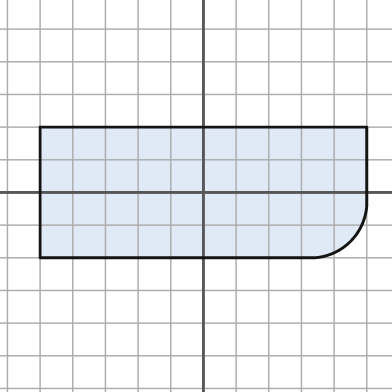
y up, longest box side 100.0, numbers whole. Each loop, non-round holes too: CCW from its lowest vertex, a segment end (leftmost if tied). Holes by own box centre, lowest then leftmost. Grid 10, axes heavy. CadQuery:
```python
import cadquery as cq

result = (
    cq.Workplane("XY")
    .moveTo(-50.0, -20.0)
    .lineTo(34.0, -20.0)
    .threePointArc((45.0, -15.0), (50.0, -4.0))
    .lineTo(50.0, 20.0)
    .lineTo(-50.0, 20.0)
    .close()
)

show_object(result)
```